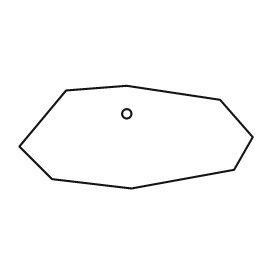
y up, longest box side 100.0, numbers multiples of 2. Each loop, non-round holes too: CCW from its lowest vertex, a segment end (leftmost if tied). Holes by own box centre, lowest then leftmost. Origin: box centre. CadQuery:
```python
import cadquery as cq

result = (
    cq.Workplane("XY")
    .moveTo(-2.0, -22.0)
    .lineTo(42.0, -14.0)
    .lineTo(50.0, 0.0)
    .lineTo(36.0, 16.0)
    .lineTo(-4.0, 22.0)
    .lineTo(-30.0, 20.0)
    .lineTo(-50.0, -4.0)
    .lineTo(-36.0, -18.0)
    .close()
    .moveTo(-4.0, 10.0)
    .circle(2.0)
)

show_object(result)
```